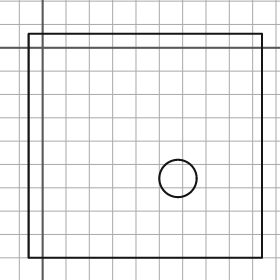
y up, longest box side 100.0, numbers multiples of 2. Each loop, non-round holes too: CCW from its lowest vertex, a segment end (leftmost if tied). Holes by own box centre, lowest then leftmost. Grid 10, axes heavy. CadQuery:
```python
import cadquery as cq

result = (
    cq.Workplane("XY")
    .moveTo(-6.0, -90.0)
    .lineTo(94.0, -90.0)
    .lineTo(94.0, 6.0)
    .lineTo(-6.0, 6.0)
    .close()
    .moveTo(58.0, -56.0)
    .circle(8.0)
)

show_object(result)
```